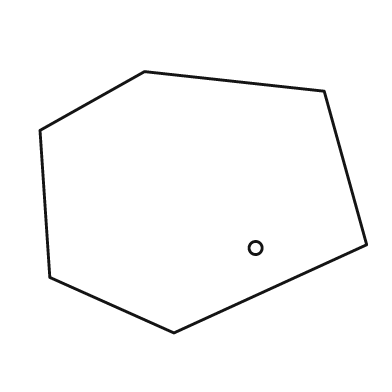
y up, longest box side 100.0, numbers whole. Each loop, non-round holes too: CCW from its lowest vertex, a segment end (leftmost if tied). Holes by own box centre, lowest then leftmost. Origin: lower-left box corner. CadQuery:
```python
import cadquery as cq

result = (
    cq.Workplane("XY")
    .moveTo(41.0, 0.0)
    .lineTo(100.0, 27.0)
    .lineTo(87.0, 74.0)
    .lineTo(32.0, 80.0)
    .lineTo(0.0, 62.0)
    .lineTo(3.0, 17.0)
    .close()
    .moveTo(66.0, 26.0)
    .circle(2.0)
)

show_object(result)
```